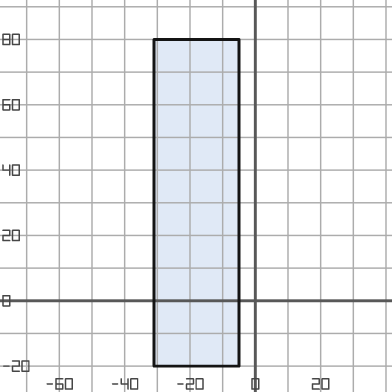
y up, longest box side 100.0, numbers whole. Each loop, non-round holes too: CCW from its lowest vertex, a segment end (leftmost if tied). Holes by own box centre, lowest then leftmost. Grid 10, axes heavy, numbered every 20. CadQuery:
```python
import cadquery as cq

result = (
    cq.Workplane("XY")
    .moveTo(-31.0, -20.0)
    .lineTo(-5.0, -20.0)
    .lineTo(-5.0, 80.0)
    .lineTo(-31.0, 80.0)
    .close()
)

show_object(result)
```